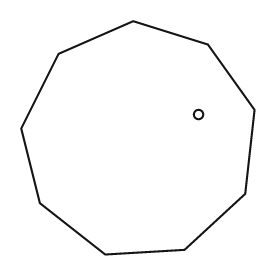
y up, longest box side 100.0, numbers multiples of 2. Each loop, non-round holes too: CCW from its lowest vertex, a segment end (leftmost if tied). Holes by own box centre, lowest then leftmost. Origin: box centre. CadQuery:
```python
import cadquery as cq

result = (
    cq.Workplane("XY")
    .moveTo(-14.0, -50.0)
    .lineTo(20.0, -48.0)
    .lineTo(46.0, -24.0)
    .lineTo(50.0, 12.0)
    .lineTo(30.0, 40.0)
    .lineTo(-2.0, 50.0)
    .lineTo(-34.0, 36.0)
    .lineTo(-50.0, 4.0)
    .lineTo(-42.0, -28.0)
    .close()
    .moveTo(26.0, 10.0)
    .circle(2.0)
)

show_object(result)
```